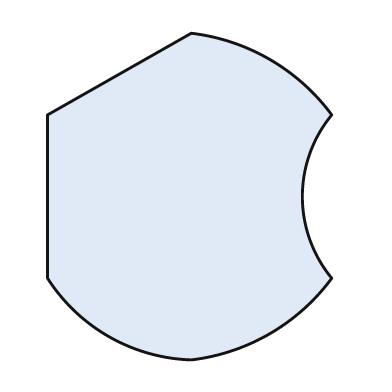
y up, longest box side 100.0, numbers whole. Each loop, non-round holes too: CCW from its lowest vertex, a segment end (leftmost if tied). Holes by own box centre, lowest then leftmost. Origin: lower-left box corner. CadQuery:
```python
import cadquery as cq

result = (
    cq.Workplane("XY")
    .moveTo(44.0, 0.0)
    .threePointArc((68.0, 8.0), (87.0, 25.0))
    .threePointArc((78.0, 50.0), (87.0, 75.0))
    .threePointArc((68.0, 92.0), (44.0, 100.0))
    .lineTo(0.0, 75.0)
    .lineTo(0.0, 25.0)
    .threePointArc((19.0, 7.0), (44.0, 0.0))
    .close()
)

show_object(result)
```